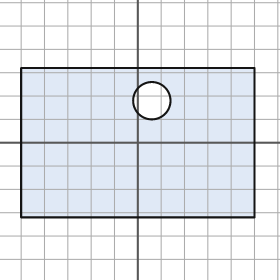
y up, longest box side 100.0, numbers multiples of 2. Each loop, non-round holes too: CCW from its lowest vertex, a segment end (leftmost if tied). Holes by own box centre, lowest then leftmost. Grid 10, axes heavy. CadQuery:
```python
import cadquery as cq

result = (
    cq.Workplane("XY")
    .moveTo(-50.0, -32.0)
    .lineTo(50.0, -32.0)
    .lineTo(50.0, 32.0)
    .lineTo(-50.0, 32.0)
    .close()
    .moveTo(6.0, 18.0)
    .circle(8.0)
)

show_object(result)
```